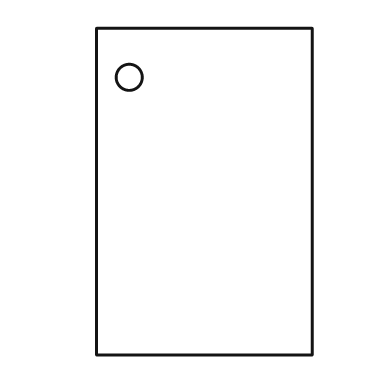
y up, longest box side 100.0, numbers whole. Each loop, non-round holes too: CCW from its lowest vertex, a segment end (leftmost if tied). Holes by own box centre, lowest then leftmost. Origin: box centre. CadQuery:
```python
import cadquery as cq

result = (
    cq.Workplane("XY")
    .moveTo(-33.0, -50.0)
    .lineTo(33.0, -50.0)
    .lineTo(33.0, 50.0)
    .lineTo(-33.0, 50.0)
    .close()
    .moveTo(-23.0, 35.0)
    .circle(4.0)
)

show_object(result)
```